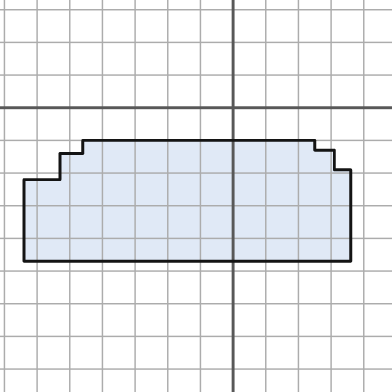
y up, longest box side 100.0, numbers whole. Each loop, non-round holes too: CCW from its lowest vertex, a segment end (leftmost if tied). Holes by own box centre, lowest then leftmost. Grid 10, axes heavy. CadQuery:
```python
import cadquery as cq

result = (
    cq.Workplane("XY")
    .moveTo(-64.0, -47.0)
    .lineTo(36.0, -47.0)
    .lineTo(36.0, -19.0)
    .lineTo(31.0, -19.0)
    .lineTo(31.0, -13.0)
    .lineTo(25.0, -13.0)
    .lineTo(25.0, -10.0)
    .lineTo(-46.0, -10.0)
    .lineTo(-46.0, -14.0)
    .lineTo(-53.0, -14.0)
    .lineTo(-53.0, -22.0)
    .lineTo(-64.0, -22.0)
    .close()
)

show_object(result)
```